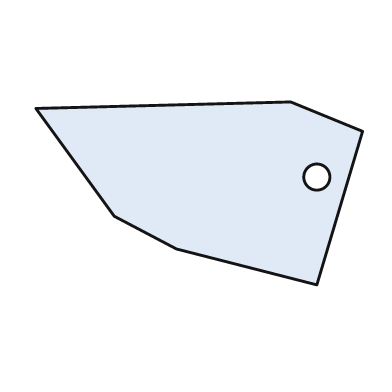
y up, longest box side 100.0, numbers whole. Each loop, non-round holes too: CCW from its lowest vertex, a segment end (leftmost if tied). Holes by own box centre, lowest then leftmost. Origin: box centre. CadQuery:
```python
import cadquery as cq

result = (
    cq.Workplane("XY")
    .moveTo(36.0, -28.0)
    .lineTo(50.0, 19.0)
    .lineTo(28.0, 28.0)
    .lineTo(-50.0, 26.0)
    .lineTo(-26.0, -7.0)
    .lineTo(-7.0, -17.0)
    .close()
    .moveTo(36.0, 5.0)
    .circle(4.0)
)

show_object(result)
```